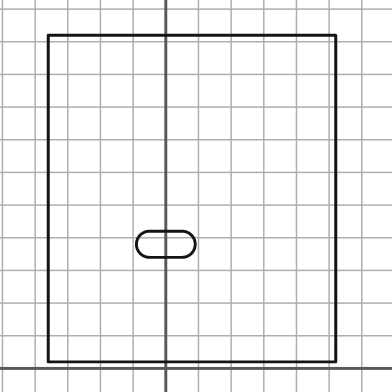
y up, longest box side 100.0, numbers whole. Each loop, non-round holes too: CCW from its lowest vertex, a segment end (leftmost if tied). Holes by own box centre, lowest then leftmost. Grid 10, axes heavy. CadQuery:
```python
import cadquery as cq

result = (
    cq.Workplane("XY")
    .moveTo(-36.0, 2.0)
    .lineTo(52.0, 2.0)
    .lineTo(52.0, 102.0)
    .lineTo(-36.0, 102.0)
    .close()
    .moveTo(-5.0, 34.0)
    .lineTo(5.0, 34.0)
    .threePointArc((9.0, 38.0), (5.0, 42.0))
    .lineTo(-5.0, 42.0)
    .threePointArc((-9.0, 38.0), (-5.0, 34.0))
    .close()
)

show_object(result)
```